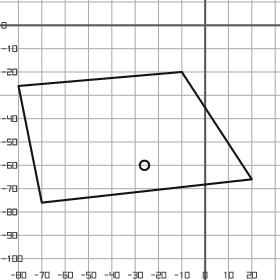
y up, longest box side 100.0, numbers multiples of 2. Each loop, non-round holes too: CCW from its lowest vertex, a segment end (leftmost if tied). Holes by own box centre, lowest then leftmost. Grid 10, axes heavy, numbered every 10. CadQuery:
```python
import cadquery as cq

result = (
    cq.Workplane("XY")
    .moveTo(-70.0, -76.0)
    .lineTo(20.0, -66.0)
    .lineTo(-10.0, -20.0)
    .lineTo(-80.0, -26.0)
    .close()
    .moveTo(-26.0, -60.0)
    .circle(2.0)
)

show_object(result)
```